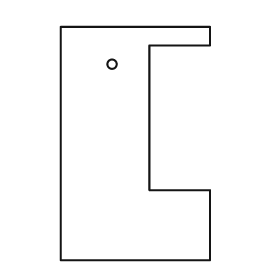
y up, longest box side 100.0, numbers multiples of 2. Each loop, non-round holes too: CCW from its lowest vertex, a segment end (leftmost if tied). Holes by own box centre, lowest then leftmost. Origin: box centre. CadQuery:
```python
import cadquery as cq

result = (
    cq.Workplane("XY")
    .moveTo(-32.0, -50.0)
    .lineTo(32.0, -50.0)
    .lineTo(32.0, -20.0)
    .lineTo(6.0, -20.0)
    .lineTo(6.0, 42.0)
    .lineTo(32.0, 42.0)
    .lineTo(32.0, 50.0)
    .lineTo(-32.0, 50.0)
    .close()
    .moveTo(-10.0, 34.0)
    .circle(2.0)
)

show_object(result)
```